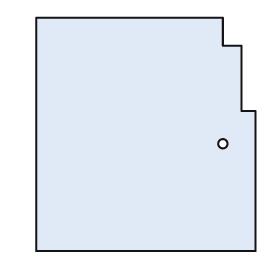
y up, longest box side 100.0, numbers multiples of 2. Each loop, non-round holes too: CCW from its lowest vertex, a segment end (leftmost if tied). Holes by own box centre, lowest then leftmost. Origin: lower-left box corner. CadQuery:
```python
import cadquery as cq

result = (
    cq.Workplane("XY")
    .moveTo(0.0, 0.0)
    .lineTo(94.0, 0.0)
    .lineTo(94.0, 60.0)
    .lineTo(88.0, 60.0)
    .lineTo(88.0, 88.0)
    .lineTo(80.0, 88.0)
    .lineTo(80.0, 100.0)
    .lineTo(0.0, 100.0)
    .close()
    .moveTo(80.0, 46.0)
    .circle(2.0)
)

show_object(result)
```